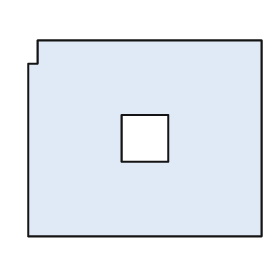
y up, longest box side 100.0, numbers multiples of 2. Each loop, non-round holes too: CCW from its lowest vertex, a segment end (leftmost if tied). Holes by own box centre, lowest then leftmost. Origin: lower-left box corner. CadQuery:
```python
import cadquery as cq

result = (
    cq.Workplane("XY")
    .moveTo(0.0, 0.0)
    .lineTo(100.0, 0.0)
    .lineTo(100.0, 84.0)
    .lineTo(4.0, 84.0)
    .lineTo(4.0, 74.0)
    .lineTo(0.0, 74.0)
    .close()
    .moveTo(40.0, 32.0)
    .lineTo(60.0, 32.0)
    .lineTo(60.0, 52.0)
    .lineTo(40.0, 52.0)
    .close()
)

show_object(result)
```